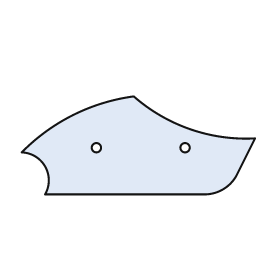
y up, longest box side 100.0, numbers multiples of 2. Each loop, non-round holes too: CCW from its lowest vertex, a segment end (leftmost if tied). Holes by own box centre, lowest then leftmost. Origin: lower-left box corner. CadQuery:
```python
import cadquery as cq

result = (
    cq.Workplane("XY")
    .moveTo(10.0, 0.0)
    .lineTo(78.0, 0.0)
    .threePointArc((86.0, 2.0), (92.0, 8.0))
    .lineTo(100.0, 24.0)
    .threePointArc((72.0, 28.0), (48.0, 42.0))
    .threePointArc((22.0, 34.0), (0.0, 18.0))
    .threePointArc((10.0, 12.0), (10.0, 0.0))
    .close()
    .moveTo(32.0, 20.0)
    .circle(2.0)
    .moveTo(70.0, 20.0)
    .circle(2.0)
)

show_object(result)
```